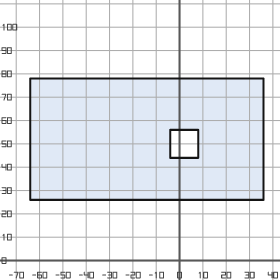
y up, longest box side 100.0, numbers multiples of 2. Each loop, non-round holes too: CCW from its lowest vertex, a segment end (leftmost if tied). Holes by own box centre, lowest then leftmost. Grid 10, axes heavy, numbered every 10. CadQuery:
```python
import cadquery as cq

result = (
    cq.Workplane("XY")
    .moveTo(-64.0, 26.0)
    .lineTo(36.0, 26.0)
    .lineTo(36.0, 78.0)
    .lineTo(-64.0, 78.0)
    .close()
    .moveTo(-4.0, 44.0)
    .lineTo(8.0, 44.0)
    .lineTo(8.0, 56.0)
    .lineTo(-4.0, 56.0)
    .close()
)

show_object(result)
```